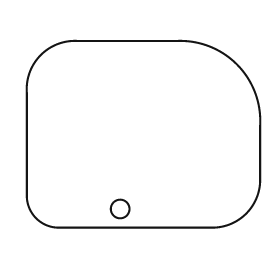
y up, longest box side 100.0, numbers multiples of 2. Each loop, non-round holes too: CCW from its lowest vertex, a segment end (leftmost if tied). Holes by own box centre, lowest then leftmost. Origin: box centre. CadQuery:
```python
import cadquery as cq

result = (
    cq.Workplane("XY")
    .moveTo(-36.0, -40.0)
    .lineTo(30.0, -40.0)
    .threePointArc((44.0, -34.0), (50.0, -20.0))
    .lineTo(50.0, 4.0)
    .threePointArc((40.0, 30.0), (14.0, 40.0))
    .lineTo(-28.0, 40.0)
    .threePointArc((-44.0, 34.0), (-50.0, 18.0))
    .lineTo(-50.0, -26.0)
    .threePointArc((-46.0, -36.0), (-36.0, -40.0))
    .close()
    .moveTo(-10.0, -32.0)
    .circle(4.0)
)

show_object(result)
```